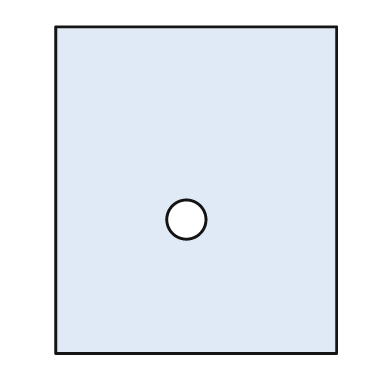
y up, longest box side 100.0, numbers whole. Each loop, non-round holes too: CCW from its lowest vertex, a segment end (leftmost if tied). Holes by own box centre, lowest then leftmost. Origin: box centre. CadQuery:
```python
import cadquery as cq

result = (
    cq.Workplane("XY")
    .moveTo(-43.0, -50.0)
    .lineTo(43.0, -50.0)
    .lineTo(43.0, 50.0)
    .lineTo(-43.0, 50.0)
    .close()
    .moveTo(-3.0, -9.0)
    .circle(6.0)
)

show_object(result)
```